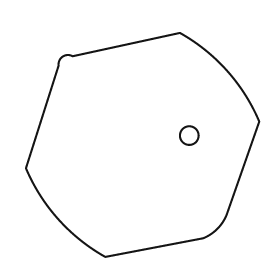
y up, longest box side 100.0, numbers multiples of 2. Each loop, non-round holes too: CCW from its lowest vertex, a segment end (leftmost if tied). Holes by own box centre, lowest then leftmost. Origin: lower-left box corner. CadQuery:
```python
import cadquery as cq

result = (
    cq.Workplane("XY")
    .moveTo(34.0, 0.0)
    .lineTo(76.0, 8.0)
    .threePointArc((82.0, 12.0), (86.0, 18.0))
    .lineTo(100.0, 58.0)
    .threePointArc((86.0, 80.0), (66.0, 96.0))
    .lineTo(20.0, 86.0)
    .threePointArc((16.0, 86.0), (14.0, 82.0))
    .lineTo(0.0, 38.0)
    .threePointArc((14.0, 16.0), (34.0, 0.0))
    .close()
    .moveTo(70.0, 52.0)
    .circle(4.0)
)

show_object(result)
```